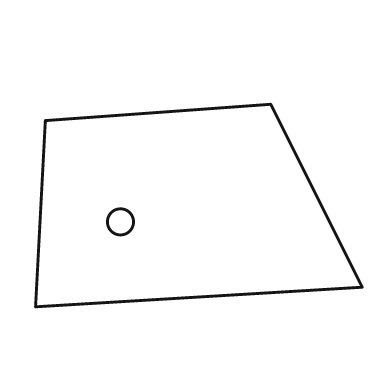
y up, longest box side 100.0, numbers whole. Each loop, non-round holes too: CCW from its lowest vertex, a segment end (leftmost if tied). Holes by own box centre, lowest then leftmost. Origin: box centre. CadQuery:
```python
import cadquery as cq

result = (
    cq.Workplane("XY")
    .moveTo(-50.0, -31.0)
    .lineTo(50.0, -25.0)
    .lineTo(22.0, 31.0)
    .lineTo(-47.0, 26.0)
    .close()
    .moveTo(-24.0, -5.0)
    .circle(4.0)
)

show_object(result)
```